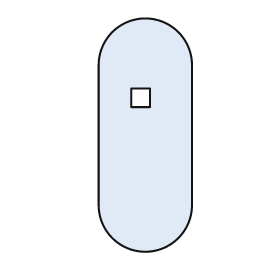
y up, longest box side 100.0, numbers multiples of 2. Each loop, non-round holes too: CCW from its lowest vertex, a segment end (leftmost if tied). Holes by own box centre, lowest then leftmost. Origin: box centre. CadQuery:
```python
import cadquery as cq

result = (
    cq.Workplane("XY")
    .moveTo(-20.0, -30.0)
    .threePointArc((0.0, -50.0), (20.0, -30.0))
    .lineTo(20.0, 30.0)
    .threePointArc((0.0, 50.0), (-20.0, 30.0))
    .close()
    .moveTo(-6.0, 12.0)
    .lineTo(2.0, 12.0)
    .lineTo(2.0, 20.0)
    .lineTo(-6.0, 20.0)
    .close()
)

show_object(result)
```